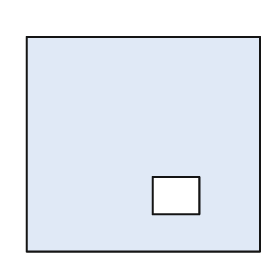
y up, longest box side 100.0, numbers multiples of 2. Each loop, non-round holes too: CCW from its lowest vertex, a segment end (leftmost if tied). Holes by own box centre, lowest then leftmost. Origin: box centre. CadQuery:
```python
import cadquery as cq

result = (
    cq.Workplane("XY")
    .moveTo(-50.0, -46.0)
    .lineTo(50.0, -46.0)
    .lineTo(50.0, 46.0)
    .lineTo(-50.0, 46.0)
    .close()
    .moveTo(4.0, -30.0)
    .lineTo(24.0, -30.0)
    .lineTo(24.0, -14.0)
    .lineTo(4.0, -14.0)
    .close()
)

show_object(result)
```